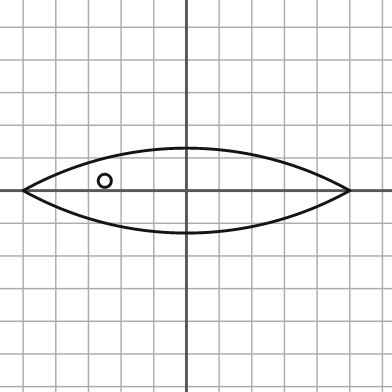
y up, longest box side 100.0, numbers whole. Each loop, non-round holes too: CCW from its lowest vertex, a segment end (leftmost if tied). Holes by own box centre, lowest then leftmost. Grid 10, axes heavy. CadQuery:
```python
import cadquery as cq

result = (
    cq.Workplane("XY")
    .moveTo(-50.0, 0.0)
    .threePointArc((0.0, -13.0), (50.0, 0.0))
    .threePointArc((0.0, 13.0), (-50.0, 0.0))
    .close()
    .moveTo(-25.0, 3.0)
    .circle(2.0)
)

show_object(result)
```